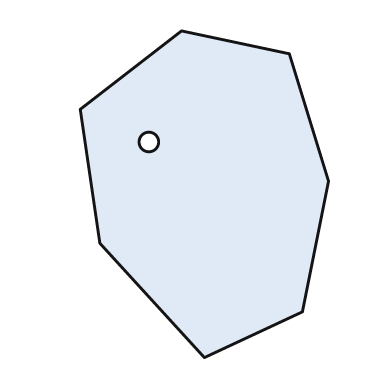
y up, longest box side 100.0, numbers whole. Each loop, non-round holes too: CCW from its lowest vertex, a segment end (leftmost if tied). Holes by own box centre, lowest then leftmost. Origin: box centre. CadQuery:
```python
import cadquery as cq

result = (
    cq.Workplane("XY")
    .moveTo(0.0, -50.0)
    .lineTo(30.0, -36.0)
    .lineTo(38.0, 4.0)
    .lineTo(26.0, 43.0)
    .lineTo(-7.0, 50.0)
    .lineTo(-38.0, 26.0)
    .lineTo(-32.0, -15.0)
    .close()
    .moveTo(-17.0, 16.0)
    .circle(3.0)
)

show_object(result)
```